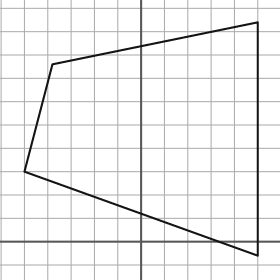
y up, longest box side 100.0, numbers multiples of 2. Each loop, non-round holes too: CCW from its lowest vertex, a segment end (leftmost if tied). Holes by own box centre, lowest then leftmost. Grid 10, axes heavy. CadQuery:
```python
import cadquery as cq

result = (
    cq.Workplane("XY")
    .moveTo(50.0, -6.0)
    .lineTo(50.0, 94.0)
    .lineTo(-38.0, 76.0)
    .lineTo(-50.0, 30.0)
    .close()
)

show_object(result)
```